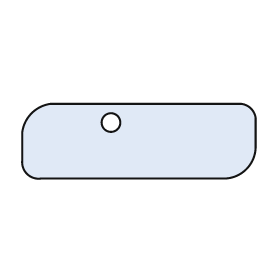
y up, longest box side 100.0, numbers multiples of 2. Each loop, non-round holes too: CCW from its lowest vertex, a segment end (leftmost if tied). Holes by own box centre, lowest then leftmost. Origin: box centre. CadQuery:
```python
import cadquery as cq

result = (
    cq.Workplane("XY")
    .moveTo(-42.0, -16.0)
    .lineTo(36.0, -16.0)
    .threePointArc((46.0, -12.0), (50.0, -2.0))
    .lineTo(50.0, 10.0)
    .threePointArc((48.0, 14.0), (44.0, 16.0))
    .lineTo(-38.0, 16.0)
    .threePointArc((-46.0, 12.0), (-50.0, 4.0))
    .lineTo(-50.0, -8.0)
    .threePointArc((-48.0, -14.0), (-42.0, -16.0))
    .close()
    .moveTo(-12.0, 8.0)
    .circle(4.0)
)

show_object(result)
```